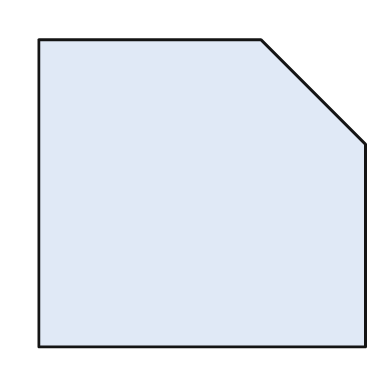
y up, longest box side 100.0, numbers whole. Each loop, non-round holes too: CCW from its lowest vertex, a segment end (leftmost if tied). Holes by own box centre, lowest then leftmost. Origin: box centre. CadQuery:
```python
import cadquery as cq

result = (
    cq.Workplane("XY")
    .moveTo(-50.0, -47.0)
    .lineTo(50.0, -47.0)
    .lineTo(50.0, 15.0)
    .lineTo(18.0, 47.0)
    .lineTo(-50.0, 47.0)
    .close()
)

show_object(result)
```